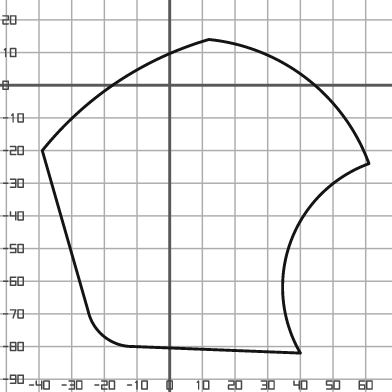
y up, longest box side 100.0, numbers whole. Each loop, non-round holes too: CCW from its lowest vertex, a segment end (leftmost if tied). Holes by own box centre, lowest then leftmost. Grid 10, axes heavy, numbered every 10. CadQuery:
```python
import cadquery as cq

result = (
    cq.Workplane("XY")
    .moveTo(40.0, -82.0)
    .threePointArc((37.0, -48.0), (61.0, -24.0))
    .threePointArc((42.0, 2.0), (12.0, 14.0))
    .threePointArc((-16.0, 1.0), (-39.0, -20.0))
    .lineTo(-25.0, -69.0)
    .threePointArc((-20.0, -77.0), (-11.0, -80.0))
    .close()
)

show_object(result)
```